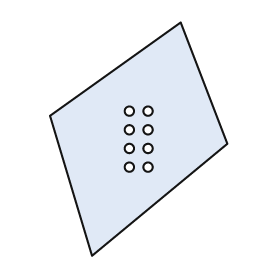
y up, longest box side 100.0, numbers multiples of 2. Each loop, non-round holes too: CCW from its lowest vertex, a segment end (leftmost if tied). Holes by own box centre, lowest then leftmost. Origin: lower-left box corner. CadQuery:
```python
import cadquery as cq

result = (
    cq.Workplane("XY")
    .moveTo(18.0, 0.0)
    .lineTo(76.0, 48.0)
    .lineTo(56.0, 100.0)
    .lineTo(0.0, 60.0)
    .close()
    .moveTo(34.0, 38.0)
    .circle(2.0)
    .moveTo(42.0, 38.0)
    .circle(2.0)
    .moveTo(34.0, 46.0)
    .circle(2.0)
    .moveTo(42.0, 46.0)
    .circle(2.0)
    .moveTo(34.0, 54.0)
    .circle(2.0)
    .moveTo(42.0, 54.0)
    .circle(2.0)
    .moveTo(34.0, 62.0)
    .circle(2.0)
    .moveTo(42.0, 62.0)
    .circle(2.0)
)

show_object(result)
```